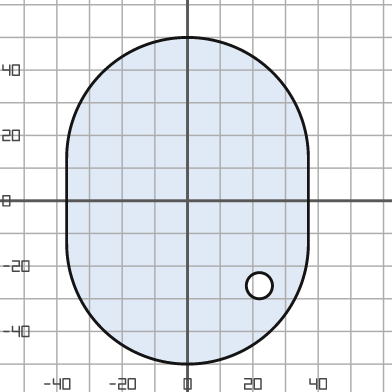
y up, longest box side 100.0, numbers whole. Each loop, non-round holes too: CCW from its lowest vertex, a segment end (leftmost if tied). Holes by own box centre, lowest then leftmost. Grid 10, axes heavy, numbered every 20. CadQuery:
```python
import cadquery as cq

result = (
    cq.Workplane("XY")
    .moveTo(-37.0, -13.0)
    .threePointArc((0.0, -50.0), (37.0, -13.0))
    .lineTo(37.0, 13.0)
    .threePointArc((0.0, 50.0), (-37.0, 13.0))
    .close()
    .moveTo(22.0, -26.0)
    .circle(4.0)
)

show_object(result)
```